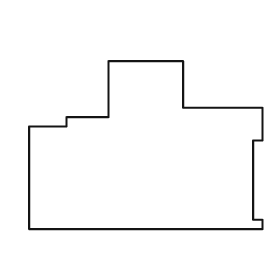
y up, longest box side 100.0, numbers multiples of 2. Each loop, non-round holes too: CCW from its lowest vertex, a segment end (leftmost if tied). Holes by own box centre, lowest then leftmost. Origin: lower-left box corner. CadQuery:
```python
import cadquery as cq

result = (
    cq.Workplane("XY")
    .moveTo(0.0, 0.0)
    .lineTo(100.0, 0.0)
    .lineTo(100.0, 4.0)
    .lineTo(96.0, 4.0)
    .lineTo(96.0, 38.0)
    .lineTo(100.0, 38.0)
    .lineTo(100.0, 52.0)
    .lineTo(66.0, 52.0)
    .lineTo(66.0, 72.0)
    .lineTo(34.0, 72.0)
    .lineTo(34.0, 48.0)
    .lineTo(16.0, 48.0)
    .lineTo(16.0, 44.0)
    .lineTo(0.0, 44.0)
    .close()
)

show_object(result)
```